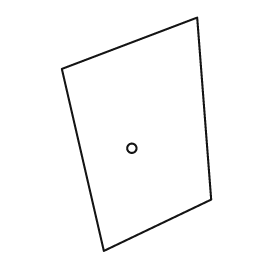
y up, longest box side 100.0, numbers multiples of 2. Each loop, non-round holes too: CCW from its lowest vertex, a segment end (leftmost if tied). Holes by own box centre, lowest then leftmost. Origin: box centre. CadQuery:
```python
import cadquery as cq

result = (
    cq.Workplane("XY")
    .moveTo(-14.0, -50.0)
    .lineTo(32.0, -28.0)
    .lineTo(26.0, 50.0)
    .lineTo(-32.0, 28.0)
    .close()
    .moveTo(-2.0, -6.0)
    .circle(2.0)
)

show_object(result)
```